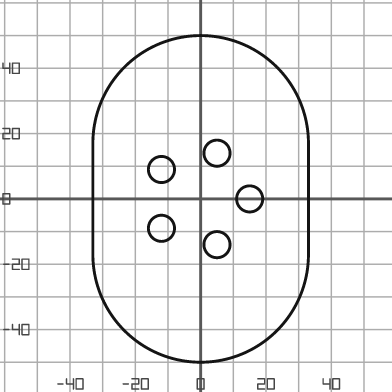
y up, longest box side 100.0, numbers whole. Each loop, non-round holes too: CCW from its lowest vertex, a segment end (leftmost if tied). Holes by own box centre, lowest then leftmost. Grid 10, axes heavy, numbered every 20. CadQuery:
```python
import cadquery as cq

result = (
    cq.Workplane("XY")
    .moveTo(-33.0, -17.0)
    .threePointArc((0.0, -50.0), (33.0, -17.0))
    .lineTo(33.0, 17.0)
    .threePointArc((0.0, 50.0), (-33.0, 17.0))
    .close()
    .moveTo(5.0, -14.0)
    .circle(4.0)
    .moveTo(-12.0, -9.0)
    .circle(4.0)
    .moveTo(15.0, 0.0)
    .circle(4.0)
    .moveTo(-12.0, 9.0)
    .circle(4.0)
    .moveTo(5.0, 14.0)
    .circle(4.0)
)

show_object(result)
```